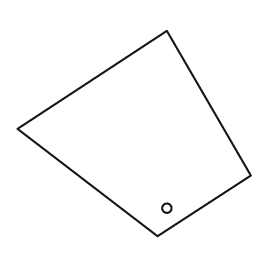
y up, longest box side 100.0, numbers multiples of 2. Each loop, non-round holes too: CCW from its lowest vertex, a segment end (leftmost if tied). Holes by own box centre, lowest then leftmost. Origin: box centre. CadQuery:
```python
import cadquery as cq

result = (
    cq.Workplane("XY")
    .moveTo(10.0, -44.0)
    .lineTo(50.0, -18.0)
    .lineTo(14.0, 44.0)
    .lineTo(-50.0, 2.0)
    .close()
    .moveTo(14.0, -32.0)
    .circle(2.0)
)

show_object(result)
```